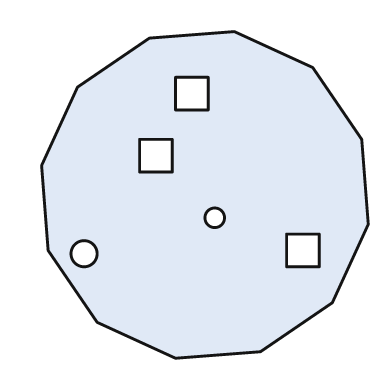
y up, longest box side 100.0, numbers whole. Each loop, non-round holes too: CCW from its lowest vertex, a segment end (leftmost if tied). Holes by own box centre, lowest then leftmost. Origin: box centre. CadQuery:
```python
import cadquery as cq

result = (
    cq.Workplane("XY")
    .moveTo(-9.0, -50.0)
    .lineTo(17.0, -48.0)
    .lineTo(39.0, -33.0)
    .lineTo(50.0, -9.0)
    .lineTo(48.0, 17.0)
    .lineTo(33.0, 39.0)
    .lineTo(9.0, 50.0)
    .lineTo(-17.0, 48.0)
    .lineTo(-39.0, 33.0)
    .lineTo(-50.0, 9.0)
    .lineTo(-48.0, -17.0)
    .lineTo(-33.0, -39.0)
    .close()
    .moveTo(-37.0, -18.0)
    .circle(4.0)
    .moveTo(25.0, -22.0)
    .lineTo(35.0, -22.0)
    .lineTo(35.0, -12.0)
    .lineTo(25.0, -12.0)
    .close()
    .moveTo(3.0, -7.0)
    .circle(3.0)
    .moveTo(-20.0, 7.0)
    .lineTo(-10.0, 7.0)
    .lineTo(-10.0, 17.0)
    .lineTo(-20.0, 17.0)
    .close()
    .moveTo(-9.0, 26.0)
    .lineTo(1.0, 26.0)
    .lineTo(1.0, 36.0)
    .lineTo(-9.0, 36.0)
    .close()
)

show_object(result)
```